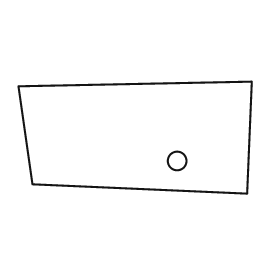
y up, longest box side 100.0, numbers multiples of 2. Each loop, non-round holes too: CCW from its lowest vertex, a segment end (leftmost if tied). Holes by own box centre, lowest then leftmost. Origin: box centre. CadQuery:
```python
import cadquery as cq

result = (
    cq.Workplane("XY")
    .moveTo(48.0, -24.0)
    .lineTo(50.0, 24.0)
    .lineTo(-50.0, 22.0)
    .lineTo(-44.0, -20.0)
    .close()
    .moveTo(18.0, -10.0)
    .circle(4.0)
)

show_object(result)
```